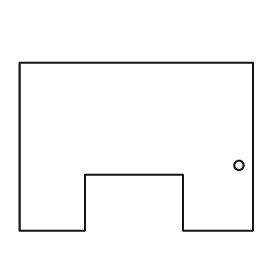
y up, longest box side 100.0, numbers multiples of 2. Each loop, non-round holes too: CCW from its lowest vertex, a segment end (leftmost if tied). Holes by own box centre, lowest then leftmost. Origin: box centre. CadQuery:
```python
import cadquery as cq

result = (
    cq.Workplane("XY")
    .moveTo(-50.0, -36.0)
    .lineTo(-22.0, -36.0)
    .lineTo(-22.0, -12.0)
    .lineTo(20.0, -12.0)
    .lineTo(20.0, -36.0)
    .lineTo(50.0, -36.0)
    .lineTo(50.0, 36.0)
    .lineTo(-50.0, 36.0)
    .close()
    .moveTo(44.0, -8.0)
    .circle(2.0)
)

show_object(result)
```